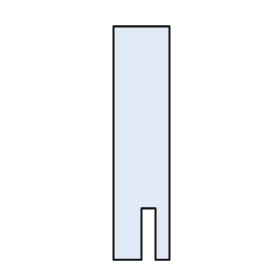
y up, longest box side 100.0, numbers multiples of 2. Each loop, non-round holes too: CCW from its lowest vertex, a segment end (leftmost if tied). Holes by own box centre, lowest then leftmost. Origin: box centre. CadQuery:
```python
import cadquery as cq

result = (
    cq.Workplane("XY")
    .moveTo(-12.0, -50.0)
    .lineTo(0.0, -50.0)
    .lineTo(0.0, -28.0)
    .lineTo(6.0, -28.0)
    .lineTo(6.0, -50.0)
    .lineTo(12.0, -50.0)
    .lineTo(12.0, 50.0)
    .lineTo(-12.0, 50.0)
    .close()
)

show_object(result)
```